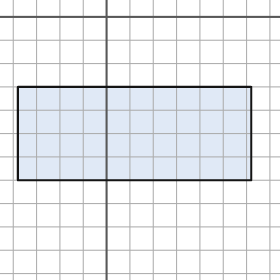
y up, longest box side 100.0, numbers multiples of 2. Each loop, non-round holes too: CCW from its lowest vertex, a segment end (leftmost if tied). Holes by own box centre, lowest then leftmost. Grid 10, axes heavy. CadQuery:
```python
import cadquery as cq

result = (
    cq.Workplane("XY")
    .moveTo(-38.0, -70.0)
    .lineTo(62.0, -70.0)
    .lineTo(62.0, -30.0)
    .lineTo(-38.0, -30.0)
    .close()
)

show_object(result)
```